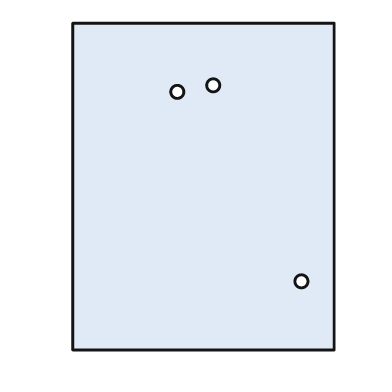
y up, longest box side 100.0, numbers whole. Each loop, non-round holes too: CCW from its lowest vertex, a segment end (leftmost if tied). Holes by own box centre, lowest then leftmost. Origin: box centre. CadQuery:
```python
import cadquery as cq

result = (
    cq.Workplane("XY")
    .moveTo(-40.0, -50.0)
    .lineTo(40.0, -50.0)
    .lineTo(40.0, 50.0)
    .lineTo(-40.0, 50.0)
    .close()
    .moveTo(30.0, -29.0)
    .circle(2.0)
    .moveTo(-8.0, 29.0)
    .circle(2.0)
    .moveTo(3.0, 31.0)
    .circle(2.0)
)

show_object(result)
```